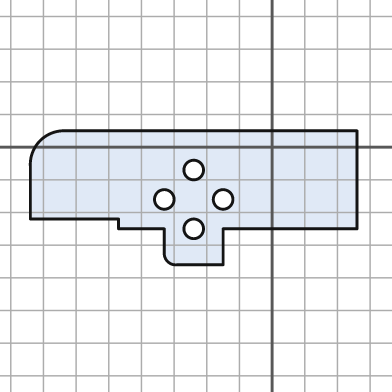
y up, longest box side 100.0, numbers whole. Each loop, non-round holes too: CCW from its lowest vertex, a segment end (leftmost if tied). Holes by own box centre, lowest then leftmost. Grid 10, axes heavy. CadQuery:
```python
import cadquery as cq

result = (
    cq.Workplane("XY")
    .moveTo(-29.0, -36.0)
    .lineTo(-15.0, -36.0)
    .lineTo(-15.0, -25.0)
    .lineTo(26.0, -25.0)
    .lineTo(26.0, 5.0)
    .lineTo(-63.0, 5.0)
    .threePointArc((-71.0, 2.0), (-74.0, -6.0))
    .lineTo(-74.0, -22.0)
    .lineTo(-47.0, -22.0)
    .lineTo(-47.0, -25.0)
    .lineTo(-33.0, -25.0)
    .lineTo(-33.0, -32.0)
    .threePointArc((-32.0, -35.0), (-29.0, -36.0))
    .close()
    .moveTo(-24.0, -25.0)
    .circle(3.0)
    .moveTo(-33.0, -16.0)
    .circle(3.0)
    .moveTo(-15.0, -16.0)
    .circle(3.0)
    .moveTo(-24.0, -7.0)
    .circle(3.0)
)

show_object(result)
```